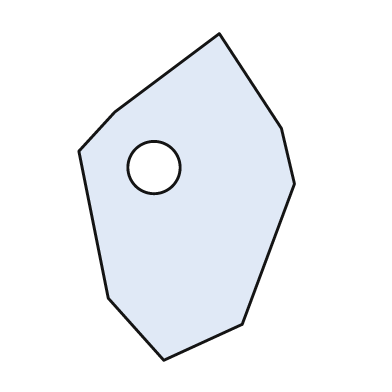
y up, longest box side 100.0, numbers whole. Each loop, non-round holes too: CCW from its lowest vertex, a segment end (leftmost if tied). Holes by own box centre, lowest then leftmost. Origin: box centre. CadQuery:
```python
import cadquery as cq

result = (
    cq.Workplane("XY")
    .moveTo(-7.0, -50.0)
    .lineTo(17.0, -39.0)
    .lineTo(33.0, 4.0)
    .lineTo(29.0, 21.0)
    .lineTo(10.0, 50.0)
    .lineTo(-22.0, 26.0)
    .lineTo(-33.0, 14.0)
    .lineTo(-24.0, -31.0)
    .close()
    .moveTo(-10.0, 9.0)
    .circle(8.0)
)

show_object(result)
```